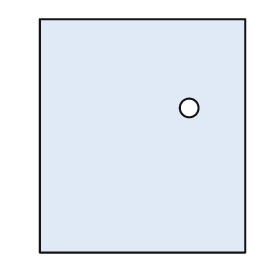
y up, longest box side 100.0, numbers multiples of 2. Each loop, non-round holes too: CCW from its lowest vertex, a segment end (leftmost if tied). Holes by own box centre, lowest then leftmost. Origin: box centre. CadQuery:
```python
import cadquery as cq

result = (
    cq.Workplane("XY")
    .moveTo(-44.0, -50.0)
    .lineTo(44.0, -50.0)
    .lineTo(44.0, 50.0)
    .lineTo(-44.0, 50.0)
    .close()
    .moveTo(20.0, 12.0)
    .circle(4.0)
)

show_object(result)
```